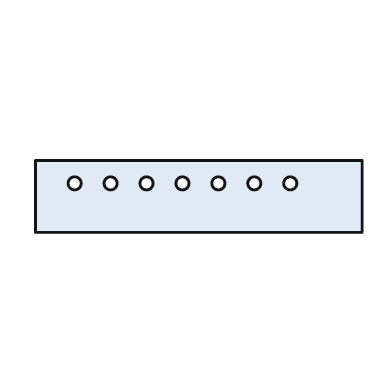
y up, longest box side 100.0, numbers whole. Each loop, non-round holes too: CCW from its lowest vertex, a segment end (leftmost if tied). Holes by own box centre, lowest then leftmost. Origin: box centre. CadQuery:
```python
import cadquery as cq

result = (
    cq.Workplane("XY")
    .moveTo(-50.0, -11.0)
    .lineTo(50.0, -11.0)
    .lineTo(50.0, 11.0)
    .lineTo(-50.0, 11.0)
    .close()
    .moveTo(-38.0, 4.0)
    .circle(2.0)
    .moveTo(-27.0, 4.0)
    .circle(2.0)
    .moveTo(-16.0, 4.0)
    .circle(2.0)
    .moveTo(-5.0, 4.0)
    .circle(2.0)
    .moveTo(6.0, 4.0)
    .circle(2.0)
    .moveTo(17.0, 4.0)
    .circle(2.0)
    .moveTo(28.0, 4.0)
    .circle(2.0)
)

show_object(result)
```